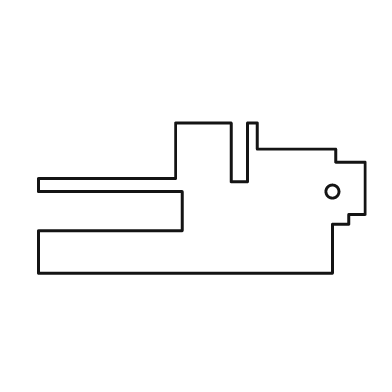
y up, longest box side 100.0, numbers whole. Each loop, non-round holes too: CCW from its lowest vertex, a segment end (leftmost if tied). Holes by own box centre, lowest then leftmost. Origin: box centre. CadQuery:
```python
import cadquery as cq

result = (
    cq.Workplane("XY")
    .moveTo(-50.0, -23.0)
    .lineTo(40.0, -23.0)
    .lineTo(40.0, -8.0)
    .lineTo(45.0, -8.0)
    .lineTo(45.0, -5.0)
    .lineTo(50.0, -5.0)
    .lineTo(50.0, 11.0)
    .lineTo(41.0, 11.0)
    .lineTo(41.0, 15.0)
    .lineTo(17.0, 15.0)
    .lineTo(17.0, 23.0)
    .lineTo(14.0, 23.0)
    .lineTo(14.0, 5.0)
    .lineTo(9.0, 5.0)
    .lineTo(9.0, 23.0)
    .lineTo(-8.0, 23.0)
    .lineTo(-8.0, 6.0)
    .lineTo(-50.0, 6.0)
    .lineTo(-50.0, 2.0)
    .lineTo(-6.0, 2.0)
    .lineTo(-6.0, -10.0)
    .lineTo(-50.0, -10.0)
    .close()
    .moveTo(40.0, 2.0)
    .circle(2.0)
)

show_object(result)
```